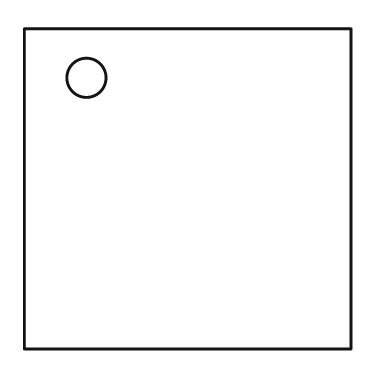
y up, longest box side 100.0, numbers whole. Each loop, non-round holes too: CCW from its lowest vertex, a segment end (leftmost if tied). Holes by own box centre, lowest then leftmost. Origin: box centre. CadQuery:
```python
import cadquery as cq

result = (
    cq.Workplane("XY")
    .moveTo(-50.0, -49.0)
    .lineTo(50.0, -49.0)
    .lineTo(50.0, 49.0)
    .lineTo(-50.0, 49.0)
    .close()
    .moveTo(-31.0, 34.0)
    .circle(6.0)
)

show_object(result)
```